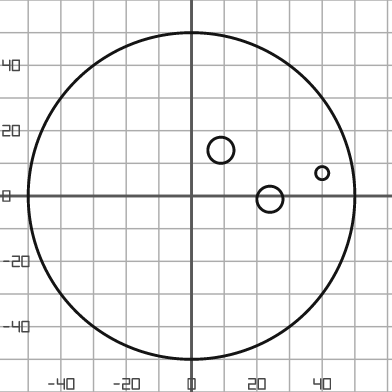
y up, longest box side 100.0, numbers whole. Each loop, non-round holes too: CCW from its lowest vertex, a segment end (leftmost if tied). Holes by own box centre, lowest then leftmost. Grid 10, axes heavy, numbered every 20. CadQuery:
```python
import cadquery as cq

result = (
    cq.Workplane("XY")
    .moveTo(0.0, 0.0)
    .circle(50.0)
    .moveTo(24.0, -1.0)
    .circle(4.0)
    .moveTo(40.0, 7.0)
    .circle(2.0)
    .moveTo(9.0, 14.0)
    .circle(4.0)
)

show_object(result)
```